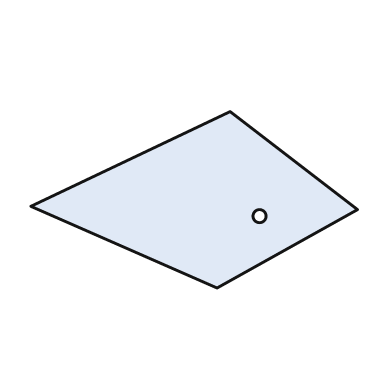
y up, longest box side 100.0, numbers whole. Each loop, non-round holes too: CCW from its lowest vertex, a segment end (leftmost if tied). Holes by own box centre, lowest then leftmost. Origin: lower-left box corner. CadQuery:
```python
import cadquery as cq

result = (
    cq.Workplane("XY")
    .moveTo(57.0, 0.0)
    .lineTo(100.0, 24.0)
    .lineTo(61.0, 54.0)
    .lineTo(0.0, 25.0)
    .close()
    .moveTo(70.0, 22.0)
    .circle(2.0)
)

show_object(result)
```